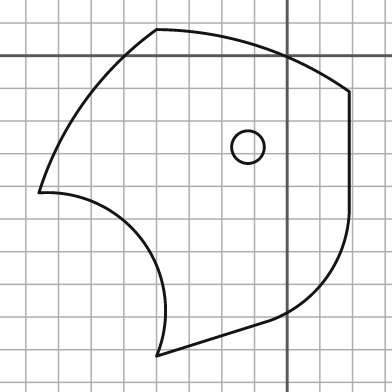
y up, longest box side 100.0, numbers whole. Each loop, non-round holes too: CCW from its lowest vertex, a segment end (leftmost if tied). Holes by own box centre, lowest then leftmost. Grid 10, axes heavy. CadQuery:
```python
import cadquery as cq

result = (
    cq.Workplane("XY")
    .moveTo(-40.0, -92.0)
    .lineTo(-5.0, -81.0)
    .threePointArc((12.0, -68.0), (19.0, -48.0))
    .lineTo(19.0, -11.0)
    .threePointArc((-9.0, 3.0), (-40.0, 8.0))
    .threePointArc((-62.0, -14.0), (-76.0, -42.0))
    .threePointArc((-44.0, -57.0), (-40.0, -92.0))
    .close()
    .moveTo(-12.0, -28.0)
    .circle(5.0)
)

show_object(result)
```